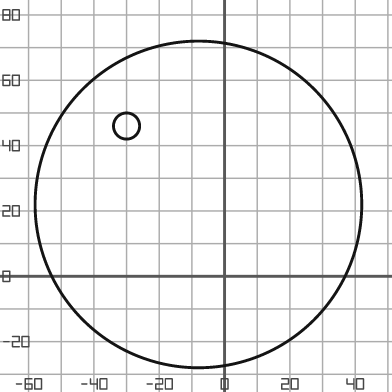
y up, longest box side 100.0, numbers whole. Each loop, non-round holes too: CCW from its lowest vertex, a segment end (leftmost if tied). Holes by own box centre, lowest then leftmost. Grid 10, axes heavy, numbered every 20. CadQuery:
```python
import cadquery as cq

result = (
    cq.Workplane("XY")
    .moveTo(-8.0, 22.0)
    .circle(50.0)
    .moveTo(-30.0, 46.0)
    .circle(4.0)
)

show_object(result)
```